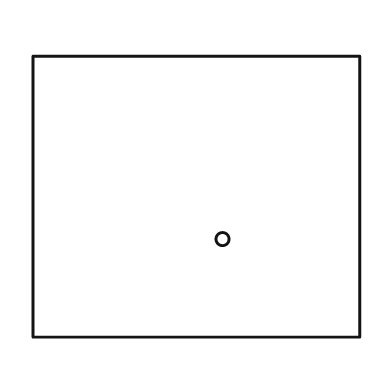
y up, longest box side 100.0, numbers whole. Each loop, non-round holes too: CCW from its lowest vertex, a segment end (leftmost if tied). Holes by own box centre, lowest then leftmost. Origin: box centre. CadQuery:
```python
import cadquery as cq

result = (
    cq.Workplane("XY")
    .moveTo(-50.0, -43.0)
    .lineTo(50.0, -43.0)
    .lineTo(50.0, 43.0)
    .lineTo(-50.0, 43.0)
    .close()
    .moveTo(8.0, -13.0)
    .circle(2.0)
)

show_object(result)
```